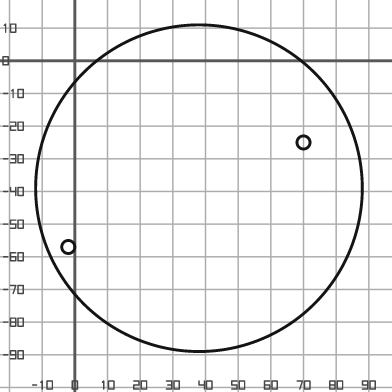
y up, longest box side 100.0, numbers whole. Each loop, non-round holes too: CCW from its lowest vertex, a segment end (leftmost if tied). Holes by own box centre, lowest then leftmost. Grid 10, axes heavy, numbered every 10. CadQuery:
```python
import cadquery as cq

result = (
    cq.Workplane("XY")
    .moveTo(38.0, -39.0)
    .circle(50.0)
    .moveTo(-2.0, -57.0)
    .circle(2.0)
    .moveTo(70.0, -25.0)
    .circle(2.0)
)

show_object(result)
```